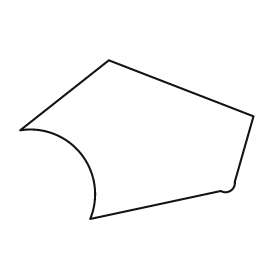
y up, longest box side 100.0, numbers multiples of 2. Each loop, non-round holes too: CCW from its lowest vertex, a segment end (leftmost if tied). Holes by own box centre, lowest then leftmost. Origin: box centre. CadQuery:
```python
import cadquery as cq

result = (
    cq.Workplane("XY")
    .moveTo(-20.0, -34.0)
    .lineTo(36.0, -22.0)
    .threePointArc((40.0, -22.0), (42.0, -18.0))
    .lineTo(50.0, 10.0)
    .lineTo(-12.0, 34.0)
    .lineTo(-50.0, 4.0)
    .threePointArc((-24.0, -6.0), (-20.0, -34.0))
    .close()
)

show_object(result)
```